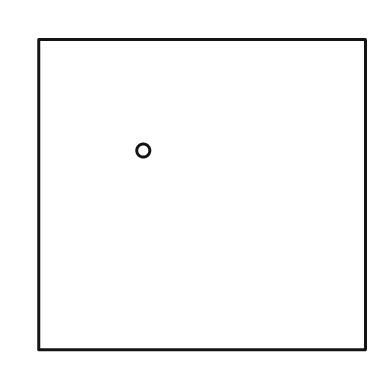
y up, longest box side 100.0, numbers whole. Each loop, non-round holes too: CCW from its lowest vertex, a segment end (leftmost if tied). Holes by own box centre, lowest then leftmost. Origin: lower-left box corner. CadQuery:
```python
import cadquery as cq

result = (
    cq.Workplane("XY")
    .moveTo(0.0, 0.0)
    .lineTo(100.0, 0.0)
    .lineTo(100.0, 95.0)
    .lineTo(0.0, 95.0)
    .close()
    .moveTo(32.0, 61.0)
    .circle(2.0)
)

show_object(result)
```